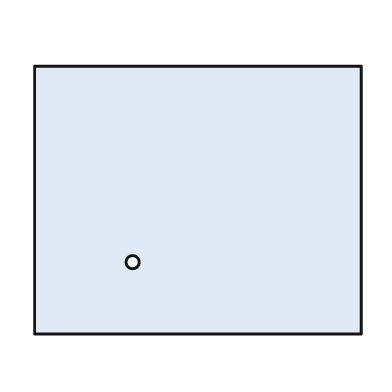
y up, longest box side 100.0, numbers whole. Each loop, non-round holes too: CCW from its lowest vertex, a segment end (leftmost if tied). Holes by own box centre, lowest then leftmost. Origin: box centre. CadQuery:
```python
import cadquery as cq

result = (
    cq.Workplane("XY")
    .moveTo(-50.0, -41.0)
    .lineTo(50.0, -41.0)
    .lineTo(50.0, 41.0)
    .lineTo(-50.0, 41.0)
    .close()
    .moveTo(-20.0, -19.0)
    .circle(2.0)
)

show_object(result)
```